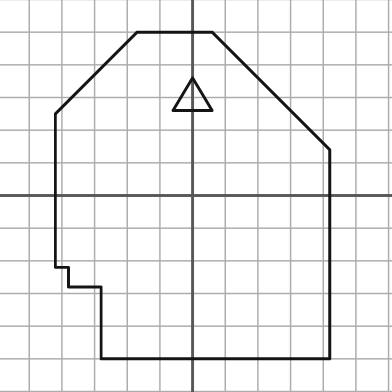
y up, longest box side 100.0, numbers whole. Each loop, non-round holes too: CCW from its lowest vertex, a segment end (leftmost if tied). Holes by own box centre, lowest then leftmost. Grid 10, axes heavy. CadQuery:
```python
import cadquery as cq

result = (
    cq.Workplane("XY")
    .moveTo(-28.0, -50.0)
    .lineTo(42.0, -50.0)
    .lineTo(42.0, 14.0)
    .lineTo(6.0, 50.0)
    .lineTo(-17.0, 50.0)
    .lineTo(-42.0, 25.0)
    .lineTo(-42.0, -22.0)
    .lineTo(-38.0, -22.0)
    .lineTo(-38.0, -28.0)
    .lineTo(-28.0, -28.0)
    .close()
    .moveTo(-6.0, 26.0)
    .lineTo(6.0, 26.0)
    .lineTo(0.0, 36.0)
    .close()
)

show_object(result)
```